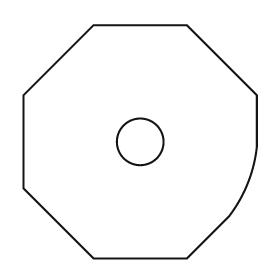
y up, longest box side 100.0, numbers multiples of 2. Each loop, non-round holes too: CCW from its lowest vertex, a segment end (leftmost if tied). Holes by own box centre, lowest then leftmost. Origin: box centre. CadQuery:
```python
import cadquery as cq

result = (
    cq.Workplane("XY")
    .moveTo(-20.0, -50.0)
    .lineTo(20.0, -50.0)
    .lineTo(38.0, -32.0)
    .threePointArc((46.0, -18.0), (50.0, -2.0))
    .lineTo(50.0, 20.0)
    .lineTo(20.0, 50.0)
    .lineTo(-20.0, 50.0)
    .lineTo(-50.0, 20.0)
    .lineTo(-50.0, -20.0)
    .close()
    .moveTo(0.0, 0.0)
    .circle(10.0)
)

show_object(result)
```